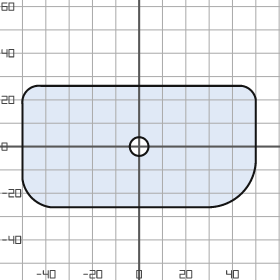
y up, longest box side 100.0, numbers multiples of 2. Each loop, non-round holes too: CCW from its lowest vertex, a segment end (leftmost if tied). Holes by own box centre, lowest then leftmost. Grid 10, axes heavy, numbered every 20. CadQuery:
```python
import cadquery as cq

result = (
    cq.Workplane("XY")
    .moveTo(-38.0, -26.0)
    .lineTo(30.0, -26.0)
    .threePointArc((44.0, -20.0), (50.0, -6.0))
    .lineTo(50.0, 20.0)
    .threePointArc((48.0, 24.0), (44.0, 26.0))
    .lineTo(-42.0, 26.0)
    .threePointArc((-48.0, 24.0), (-50.0, 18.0))
    .lineTo(-50.0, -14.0)
    .threePointArc((-46.0, -22.0), (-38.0, -26.0))
    .close()
    .moveTo(0.0, 0.0)
    .circle(4.0)
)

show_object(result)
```